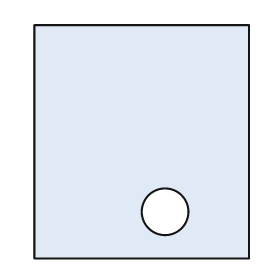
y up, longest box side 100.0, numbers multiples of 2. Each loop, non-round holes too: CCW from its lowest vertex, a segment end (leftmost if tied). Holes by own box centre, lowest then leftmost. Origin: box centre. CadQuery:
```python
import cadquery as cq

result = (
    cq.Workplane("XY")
    .moveTo(-46.0, -50.0)
    .lineTo(46.0, -50.0)
    .lineTo(46.0, 50.0)
    .lineTo(-46.0, 50.0)
    .close()
    .moveTo(10.0, -30.0)
    .circle(10.0)
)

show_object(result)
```